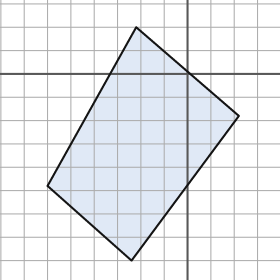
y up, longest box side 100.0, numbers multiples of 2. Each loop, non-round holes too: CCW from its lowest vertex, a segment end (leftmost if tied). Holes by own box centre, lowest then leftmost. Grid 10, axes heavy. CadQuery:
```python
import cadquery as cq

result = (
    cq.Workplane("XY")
    .moveTo(-24.0, -80.0)
    .lineTo(22.0, -18.0)
    .lineTo(-22.0, 20.0)
    .lineTo(-60.0, -48.0)
    .close()
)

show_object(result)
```